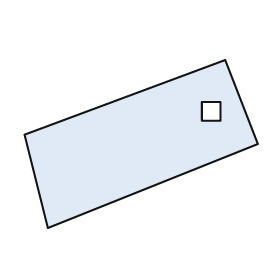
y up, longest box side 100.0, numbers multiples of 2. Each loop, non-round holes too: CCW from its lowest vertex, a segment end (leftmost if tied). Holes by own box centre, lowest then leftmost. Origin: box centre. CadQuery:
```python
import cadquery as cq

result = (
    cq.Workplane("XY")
    .moveTo(-40.0, -36.0)
    .lineTo(50.0, 0.0)
    .lineTo(36.0, 36.0)
    .lineTo(-50.0, 4.0)
    .close()
    .moveTo(26.0, 10.0)
    .lineTo(34.0, 10.0)
    .lineTo(34.0, 18.0)
    .lineTo(26.0, 18.0)
    .close()
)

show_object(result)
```